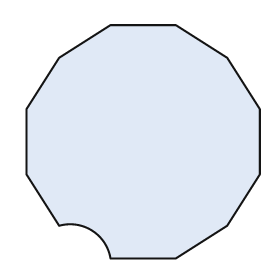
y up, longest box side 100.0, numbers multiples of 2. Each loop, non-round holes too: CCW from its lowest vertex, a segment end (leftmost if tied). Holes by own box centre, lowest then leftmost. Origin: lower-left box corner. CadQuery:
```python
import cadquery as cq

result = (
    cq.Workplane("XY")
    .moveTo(36.0, 0.0)
    .lineTo(64.0, 0.0)
    .lineTo(86.0, 14.0)
    .lineTo(100.0, 36.0)
    .lineTo(100.0, 64.0)
    .lineTo(86.0, 86.0)
    .lineTo(64.0, 100.0)
    .lineTo(36.0, 100.0)
    .lineTo(14.0, 86.0)
    .lineTo(0.0, 64.0)
    .lineTo(0.0, 36.0)
    .lineTo(14.0, 14.0)
    .threePointArc((28.0, 12.0), (36.0, 0.0))
    .close()
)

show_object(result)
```